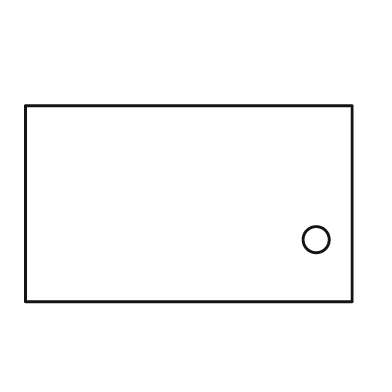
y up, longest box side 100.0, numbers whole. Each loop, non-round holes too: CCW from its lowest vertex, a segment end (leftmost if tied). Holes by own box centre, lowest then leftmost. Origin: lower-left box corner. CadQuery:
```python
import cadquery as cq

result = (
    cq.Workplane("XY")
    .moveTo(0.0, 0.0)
    .lineTo(100.0, 0.0)
    .lineTo(100.0, 60.0)
    .lineTo(0.0, 60.0)
    .close()
    .moveTo(89.0, 19.0)
    .circle(4.0)
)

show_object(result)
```